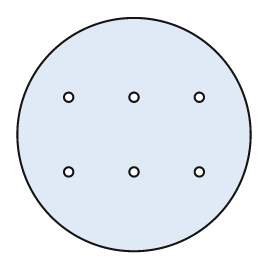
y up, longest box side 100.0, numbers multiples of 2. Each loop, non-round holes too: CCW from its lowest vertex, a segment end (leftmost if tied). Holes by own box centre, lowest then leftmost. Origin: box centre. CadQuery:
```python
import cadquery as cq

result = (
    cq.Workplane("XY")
    .moveTo(0.0, 0.0)
    .circle(50.0)
    .moveTo(-28.0, -16.0)
    .circle(2.0)
    .moveTo(0.0, -16.0)
    .circle(2.0)
    .moveTo(28.0, -16.0)
    .circle(2.0)
    .moveTo(-28.0, 16.0)
    .circle(2.0)
    .moveTo(0.0, 16.0)
    .circle(2.0)
    .moveTo(28.0, 16.0)
    .circle(2.0)
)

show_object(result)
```